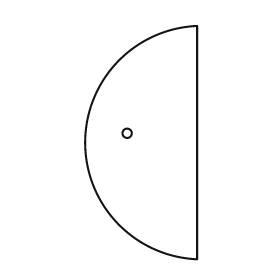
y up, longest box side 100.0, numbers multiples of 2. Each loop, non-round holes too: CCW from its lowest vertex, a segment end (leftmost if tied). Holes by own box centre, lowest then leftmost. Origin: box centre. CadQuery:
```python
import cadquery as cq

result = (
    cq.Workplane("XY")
    .moveTo(24.0, -50.0)
    .lineTo(24.0, 50.0)
    .threePointArc((-24.0, 0.0), (24.0, -50.0))
    .close()
    .moveTo(-6.0, 4.0)
    .circle(2.0)
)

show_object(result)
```